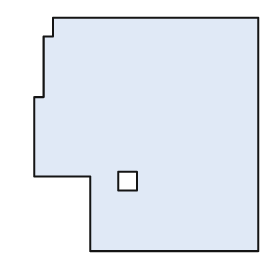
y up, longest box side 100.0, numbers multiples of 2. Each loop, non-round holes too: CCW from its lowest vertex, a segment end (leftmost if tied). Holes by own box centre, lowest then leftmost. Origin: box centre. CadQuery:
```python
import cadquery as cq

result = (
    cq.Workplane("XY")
    .moveTo(-24.0, -50.0)
    .lineTo(48.0, -50.0)
    .lineTo(48.0, 50.0)
    .lineTo(-40.0, 50.0)
    .lineTo(-40.0, 42.0)
    .lineTo(-44.0, 42.0)
    .lineTo(-44.0, 16.0)
    .lineTo(-48.0, 16.0)
    .lineTo(-48.0, -18.0)
    .lineTo(-24.0, -18.0)
    .close()
    .moveTo(-12.0, -24.0)
    .lineTo(-4.0, -24.0)
    .lineTo(-4.0, -16.0)
    .lineTo(-12.0, -16.0)
    .close()
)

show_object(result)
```